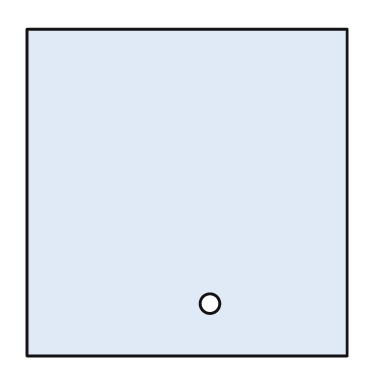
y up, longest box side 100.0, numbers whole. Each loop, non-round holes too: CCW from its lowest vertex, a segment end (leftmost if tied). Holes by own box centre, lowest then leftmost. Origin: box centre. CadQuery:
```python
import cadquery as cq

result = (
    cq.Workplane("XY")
    .moveTo(-49.0, -50.0)
    .lineTo(49.0, -50.0)
    .lineTo(49.0, 50.0)
    .lineTo(-49.0, 50.0)
    .close()
    .moveTo(7.0, -34.0)
    .circle(3.0)
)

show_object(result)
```